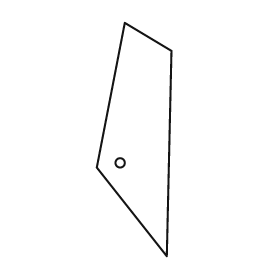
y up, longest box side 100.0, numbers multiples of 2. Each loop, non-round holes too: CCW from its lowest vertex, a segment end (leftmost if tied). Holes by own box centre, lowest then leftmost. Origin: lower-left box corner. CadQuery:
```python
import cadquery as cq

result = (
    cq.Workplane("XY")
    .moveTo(30.0, 0.0)
    .lineTo(32.0, 88.0)
    .lineTo(12.0, 100.0)
    .lineTo(0.0, 38.0)
    .close()
    .moveTo(10.0, 40.0)
    .circle(2.0)
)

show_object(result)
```